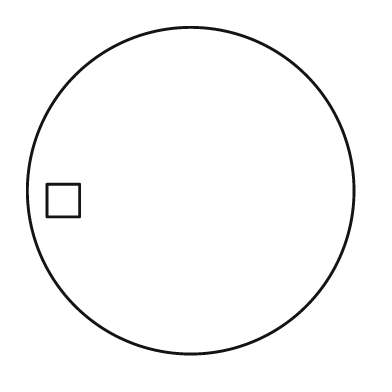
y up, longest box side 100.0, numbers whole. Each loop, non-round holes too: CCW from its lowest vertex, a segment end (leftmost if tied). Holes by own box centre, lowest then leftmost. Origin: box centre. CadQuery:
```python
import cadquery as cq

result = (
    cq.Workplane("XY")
    .moveTo(0.0, 0.0)
    .circle(50.0)
    .moveTo(-44.0, -8.0)
    .lineTo(-34.0, -8.0)
    .lineTo(-34.0, 2.0)
    .lineTo(-44.0, 2.0)
    .close()
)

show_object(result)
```